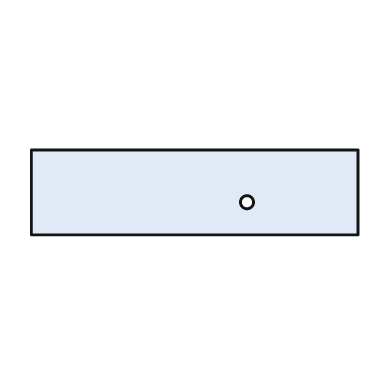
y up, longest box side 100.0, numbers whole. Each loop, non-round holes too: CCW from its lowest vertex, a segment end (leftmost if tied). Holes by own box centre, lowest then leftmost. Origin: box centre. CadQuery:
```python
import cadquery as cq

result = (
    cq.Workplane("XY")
    .moveTo(-50.0, -13.0)
    .lineTo(50.0, -13.0)
    .lineTo(50.0, 13.0)
    .lineTo(-50.0, 13.0)
    .close()
    .moveTo(16.0, -3.0)
    .circle(2.0)
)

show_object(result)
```